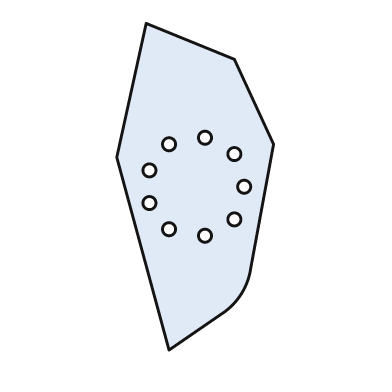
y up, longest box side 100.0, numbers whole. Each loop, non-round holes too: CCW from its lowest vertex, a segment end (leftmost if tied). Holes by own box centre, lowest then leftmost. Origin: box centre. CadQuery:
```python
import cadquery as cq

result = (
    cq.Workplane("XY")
    .moveTo(-8.0, -50.0)
    .lineTo(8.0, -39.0)
    .threePointArc((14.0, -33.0), (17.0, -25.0))
    .lineTo(24.0, 13.0)
    .lineTo(12.0, 39.0)
    .lineTo(-15.0, 50.0)
    .lineTo(-24.0, 9.0)
    .close()
    .moveTo(3.0, -15.0)
    .circle(2.0)
    .moveTo(-8.0, -13.0)
    .circle(2.0)
    .moveTo(12.0, -10.0)
    .circle(2.0)
    .moveTo(-14.0, -5.0)
    .circle(2.0)
    .moveTo(15.0, 0.0)
    .circle(2.0)
    .moveTo(-14.0, 5.0)
    .circle(2.0)
    .moveTo(12.0, 10.0)
    .circle(2.0)
    .moveTo(-8.0, 13.0)
    .circle(2.0)
    .moveTo(3.0, 15.0)
    .circle(2.0)
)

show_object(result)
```